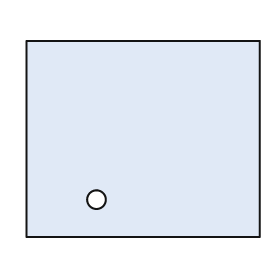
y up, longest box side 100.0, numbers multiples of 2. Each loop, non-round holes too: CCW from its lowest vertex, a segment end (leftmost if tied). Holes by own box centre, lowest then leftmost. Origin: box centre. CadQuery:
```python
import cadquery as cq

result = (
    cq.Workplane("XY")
    .moveTo(-50.0, -42.0)
    .lineTo(50.0, -42.0)
    .lineTo(50.0, 42.0)
    .lineTo(-50.0, 42.0)
    .close()
    .moveTo(-20.0, -26.0)
    .circle(4.0)
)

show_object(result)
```